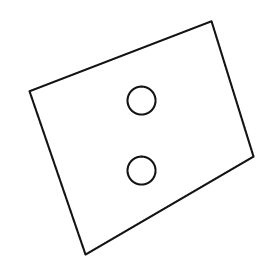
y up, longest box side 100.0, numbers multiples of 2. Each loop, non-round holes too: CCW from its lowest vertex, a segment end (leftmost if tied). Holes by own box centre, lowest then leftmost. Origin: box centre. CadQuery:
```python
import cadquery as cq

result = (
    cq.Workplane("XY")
    .moveTo(-24.0, -50.0)
    .lineTo(48.0, -8.0)
    .lineTo(30.0, 50.0)
    .lineTo(-48.0, 20.0)
    .close()
    .moveTo(0.0, -14.0)
    .circle(6.0)
    .moveTo(0.0, 16.0)
    .circle(6.0)
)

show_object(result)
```